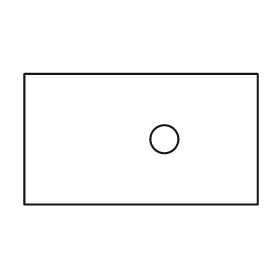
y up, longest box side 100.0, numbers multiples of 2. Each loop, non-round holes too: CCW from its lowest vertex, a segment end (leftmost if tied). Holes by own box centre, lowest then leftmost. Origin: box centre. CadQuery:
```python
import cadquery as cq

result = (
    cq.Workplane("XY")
    .moveTo(-50.0, -28.0)
    .lineTo(50.0, -28.0)
    .lineTo(50.0, 28.0)
    .lineTo(-50.0, 28.0)
    .close()
    .moveTo(10.0, 0.0)
    .circle(6.0)
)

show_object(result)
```